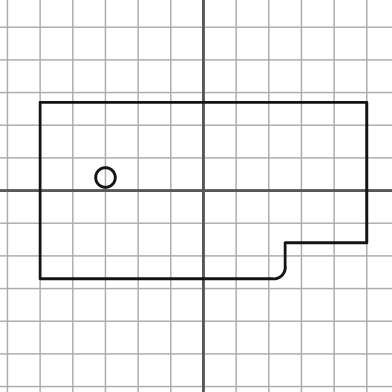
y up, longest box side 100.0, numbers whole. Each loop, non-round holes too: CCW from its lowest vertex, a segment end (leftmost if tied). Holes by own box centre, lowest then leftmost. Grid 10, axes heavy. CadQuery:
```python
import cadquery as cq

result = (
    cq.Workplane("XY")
    .moveTo(-50.0, -27.0)
    .lineTo(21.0, -27.0)
    .threePointArc((24.0, -26.0), (25.0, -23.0))
    .lineTo(25.0, -16.0)
    .lineTo(50.0, -16.0)
    .lineTo(50.0, 27.0)
    .lineTo(-50.0, 27.0)
    .close()
    .moveTo(-30.0, 4.0)
    .circle(3.0)
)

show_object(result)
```